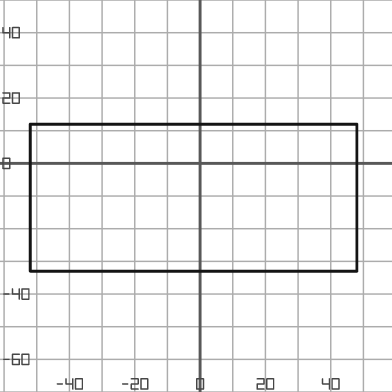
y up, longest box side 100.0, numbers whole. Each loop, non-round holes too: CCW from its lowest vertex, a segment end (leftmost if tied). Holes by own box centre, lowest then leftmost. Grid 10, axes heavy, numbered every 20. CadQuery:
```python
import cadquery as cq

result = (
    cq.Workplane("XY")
    .moveTo(-52.0, -33.0)
    .lineTo(48.0, -33.0)
    .lineTo(48.0, 12.0)
    .lineTo(-52.0, 12.0)
    .close()
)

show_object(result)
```